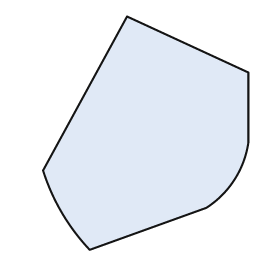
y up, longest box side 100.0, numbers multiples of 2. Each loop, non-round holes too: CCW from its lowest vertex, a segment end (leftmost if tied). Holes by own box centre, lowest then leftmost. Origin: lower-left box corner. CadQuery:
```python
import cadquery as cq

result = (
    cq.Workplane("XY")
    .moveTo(20.0, 0.0)
    .lineTo(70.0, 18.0)
    .threePointArc((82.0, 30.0), (88.0, 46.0))
    .lineTo(88.0, 76.0)
    .lineTo(36.0, 100.0)
    .lineTo(0.0, 34.0)
    .threePointArc((8.0, 16.0), (20.0, 0.0))
    .close()
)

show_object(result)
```